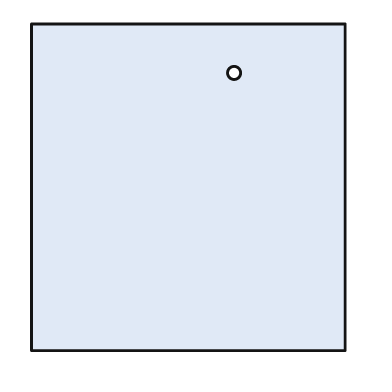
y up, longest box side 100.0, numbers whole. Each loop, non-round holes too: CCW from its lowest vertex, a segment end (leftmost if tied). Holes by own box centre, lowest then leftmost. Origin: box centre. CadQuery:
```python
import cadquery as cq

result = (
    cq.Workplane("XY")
    .moveTo(-48.0, -50.0)
    .lineTo(48.0, -50.0)
    .lineTo(48.0, 50.0)
    .lineTo(-48.0, 50.0)
    .close()
    .moveTo(14.0, 35.0)
    .circle(2.0)
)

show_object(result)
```